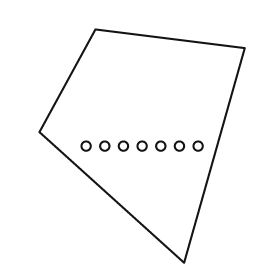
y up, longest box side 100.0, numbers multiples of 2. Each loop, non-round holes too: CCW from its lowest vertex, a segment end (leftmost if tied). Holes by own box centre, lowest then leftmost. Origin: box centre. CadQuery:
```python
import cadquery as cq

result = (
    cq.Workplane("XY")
    .moveTo(18.0, -50.0)
    .lineTo(44.0, 42.0)
    .lineTo(-20.0, 50.0)
    .lineTo(-44.0, 6.0)
    .close()
    .moveTo(-24.0, 0.0)
    .circle(2.0)
    .moveTo(-16.0, 0.0)
    .circle(2.0)
    .moveTo(-8.0, 0.0)
    .circle(2.0)
    .moveTo(0.0, 0.0)
    .circle(2.0)
    .moveTo(8.0, 0.0)
    .circle(2.0)
    .moveTo(16.0, 0.0)
    .circle(2.0)
    .moveTo(24.0, 0.0)
    .circle(2.0)
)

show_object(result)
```